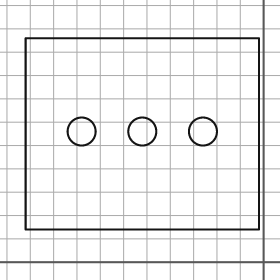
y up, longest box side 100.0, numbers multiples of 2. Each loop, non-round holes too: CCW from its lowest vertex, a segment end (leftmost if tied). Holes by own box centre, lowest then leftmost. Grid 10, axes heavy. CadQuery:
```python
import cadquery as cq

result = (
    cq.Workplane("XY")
    .moveTo(-102.0, 14.0)
    .lineTo(-2.0, 14.0)
    .lineTo(-2.0, 96.0)
    .lineTo(-102.0, 96.0)
    .close()
    .moveTo(-78.0, 56.0)
    .circle(6.0)
    .moveTo(-52.0, 56.0)
    .circle(6.0)
    .moveTo(-26.0, 56.0)
    .circle(6.0)
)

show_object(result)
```